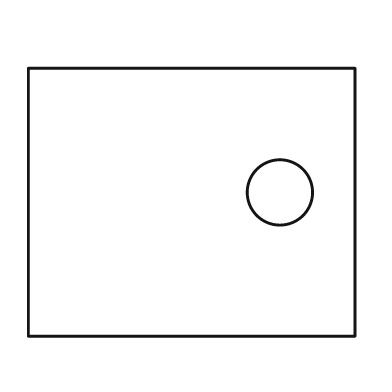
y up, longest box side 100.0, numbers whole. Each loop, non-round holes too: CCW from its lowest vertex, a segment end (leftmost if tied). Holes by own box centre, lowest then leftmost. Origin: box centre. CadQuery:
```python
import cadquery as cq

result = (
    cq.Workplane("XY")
    .moveTo(-50.0, -41.0)
    .lineTo(50.0, -41.0)
    .lineTo(50.0, 41.0)
    .lineTo(-50.0, 41.0)
    .close()
    .moveTo(27.0, 3.0)
    .circle(10.0)
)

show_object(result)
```